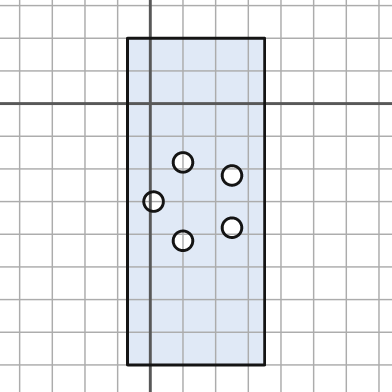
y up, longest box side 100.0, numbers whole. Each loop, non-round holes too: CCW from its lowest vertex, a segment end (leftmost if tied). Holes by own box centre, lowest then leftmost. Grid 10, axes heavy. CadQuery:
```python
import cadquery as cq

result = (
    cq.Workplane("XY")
    .moveTo(-7.0, -80.0)
    .lineTo(35.0, -80.0)
    .lineTo(35.0, 20.0)
    .lineTo(-7.0, 20.0)
    .close()
    .moveTo(10.0, -42.0)
    .circle(3.0)
    .moveTo(25.0, -38.0)
    .circle(3.0)
    .moveTo(1.0, -30.0)
    .circle(3.0)
    .moveTo(25.0, -22.0)
    .circle(3.0)
    .moveTo(10.0, -18.0)
    .circle(3.0)
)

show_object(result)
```